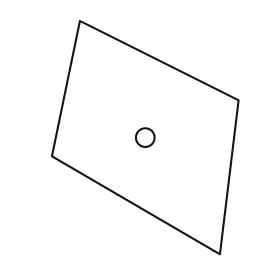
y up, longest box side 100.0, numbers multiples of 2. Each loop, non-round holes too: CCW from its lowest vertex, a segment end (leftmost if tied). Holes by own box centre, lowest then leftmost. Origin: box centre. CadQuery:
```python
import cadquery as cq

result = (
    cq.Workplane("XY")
    .moveTo(32.0, -50.0)
    .lineTo(40.0, 16.0)
    .lineTo(-28.0, 50.0)
    .lineTo(-40.0, -8.0)
    .close()
    .moveTo(0.0, 0.0)
    .circle(4.0)
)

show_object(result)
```